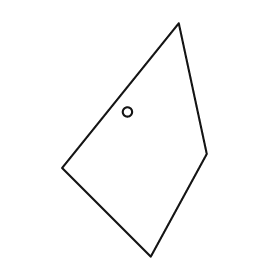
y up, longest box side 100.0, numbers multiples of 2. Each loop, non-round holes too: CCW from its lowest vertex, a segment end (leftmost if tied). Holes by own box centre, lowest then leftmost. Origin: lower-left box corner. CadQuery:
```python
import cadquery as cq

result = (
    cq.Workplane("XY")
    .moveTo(38.0, 0.0)
    .lineTo(62.0, 44.0)
    .lineTo(50.0, 100.0)
    .lineTo(0.0, 38.0)
    .close()
    .moveTo(28.0, 62.0)
    .circle(2.0)
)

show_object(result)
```